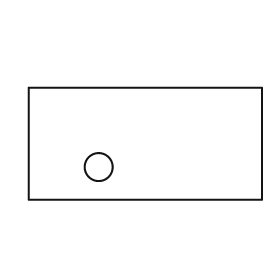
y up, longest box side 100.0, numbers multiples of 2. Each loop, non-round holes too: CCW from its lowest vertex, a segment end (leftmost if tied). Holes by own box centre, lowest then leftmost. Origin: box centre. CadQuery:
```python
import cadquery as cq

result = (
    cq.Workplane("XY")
    .moveTo(-50.0, -24.0)
    .lineTo(50.0, -24.0)
    .lineTo(50.0, 24.0)
    .lineTo(-50.0, 24.0)
    .close()
    .moveTo(-20.0, -10.0)
    .circle(6.0)
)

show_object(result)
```